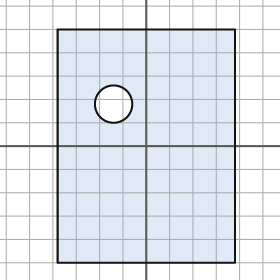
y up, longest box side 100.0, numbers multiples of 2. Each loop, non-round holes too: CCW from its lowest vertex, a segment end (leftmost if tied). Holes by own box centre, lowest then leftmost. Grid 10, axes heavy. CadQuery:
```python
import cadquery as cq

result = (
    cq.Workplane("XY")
    .moveTo(-38.0, -50.0)
    .lineTo(38.0, -50.0)
    .lineTo(38.0, 50.0)
    .lineTo(-38.0, 50.0)
    .close()
    .moveTo(-14.0, 18.0)
    .circle(8.0)
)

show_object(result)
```